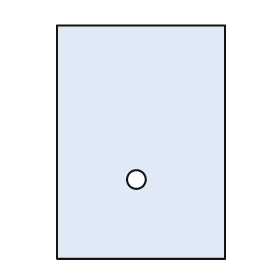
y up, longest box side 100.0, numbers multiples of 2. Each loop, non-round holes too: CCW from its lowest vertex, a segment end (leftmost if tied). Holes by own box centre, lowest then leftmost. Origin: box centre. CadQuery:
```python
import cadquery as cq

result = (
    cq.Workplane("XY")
    .moveTo(-36.0, -50.0)
    .lineTo(36.0, -50.0)
    .lineTo(36.0, 50.0)
    .lineTo(-36.0, 50.0)
    .close()
    .moveTo(-2.0, -16.0)
    .circle(4.0)
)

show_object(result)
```